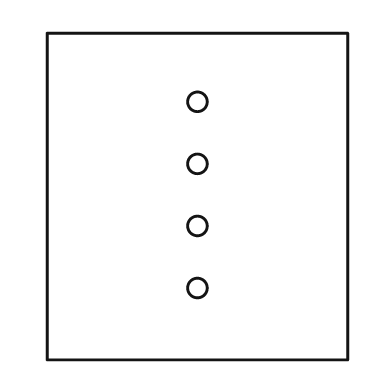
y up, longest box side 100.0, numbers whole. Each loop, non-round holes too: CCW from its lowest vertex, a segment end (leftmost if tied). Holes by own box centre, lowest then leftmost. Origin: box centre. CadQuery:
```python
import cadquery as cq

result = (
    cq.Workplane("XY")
    .moveTo(-46.0, -50.0)
    .lineTo(46.0, -50.0)
    .lineTo(46.0, 50.0)
    .lineTo(-46.0, 50.0)
    .close()
    .moveTo(0.0, -28.0)
    .circle(3.0)
    .moveTo(0.0, -9.0)
    .circle(3.0)
    .moveTo(0.0, 10.0)
    .circle(3.0)
    .moveTo(0.0, 29.0)
    .circle(3.0)
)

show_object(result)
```